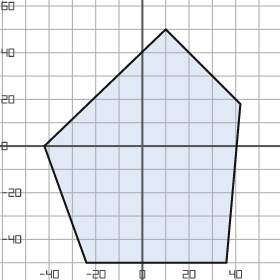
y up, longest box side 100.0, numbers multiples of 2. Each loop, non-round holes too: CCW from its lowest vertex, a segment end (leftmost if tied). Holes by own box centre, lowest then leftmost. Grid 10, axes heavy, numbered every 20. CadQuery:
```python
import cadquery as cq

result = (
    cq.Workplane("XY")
    .moveTo(-24.0, -50.0)
    .lineTo(36.0, -50.0)
    .lineTo(42.0, 18.0)
    .lineTo(10.0, 50.0)
    .lineTo(-42.0, 0.0)
    .close()
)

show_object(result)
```